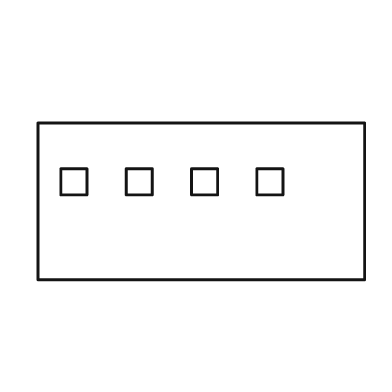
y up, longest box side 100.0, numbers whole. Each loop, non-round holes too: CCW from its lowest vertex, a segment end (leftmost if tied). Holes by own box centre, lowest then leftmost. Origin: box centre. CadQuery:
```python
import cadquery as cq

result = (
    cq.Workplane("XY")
    .moveTo(-50.0, -24.0)
    .lineTo(50.0, -24.0)
    .lineTo(50.0, 24.0)
    .lineTo(-50.0, 24.0)
    .close()
    .moveTo(-43.0, 2.0)
    .lineTo(-35.0, 2.0)
    .lineTo(-35.0, 10.0)
    .lineTo(-43.0, 10.0)
    .close()
    .moveTo(-23.0, 2.0)
    .lineTo(-15.0, 2.0)
    .lineTo(-15.0, 10.0)
    .lineTo(-23.0, 10.0)
    .close()
    .moveTo(-3.0, 2.0)
    .lineTo(5.0, 2.0)
    .lineTo(5.0, 10.0)
    .lineTo(-3.0, 10.0)
    .close()
    .moveTo(17.0, 2.0)
    .lineTo(25.0, 2.0)
    .lineTo(25.0, 10.0)
    .lineTo(17.0, 10.0)
    .close()
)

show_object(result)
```